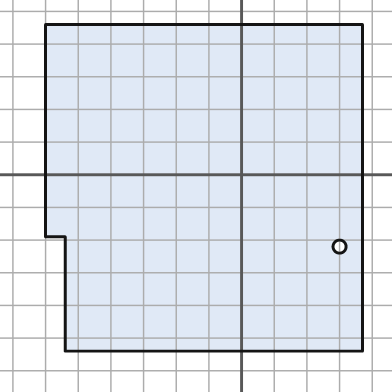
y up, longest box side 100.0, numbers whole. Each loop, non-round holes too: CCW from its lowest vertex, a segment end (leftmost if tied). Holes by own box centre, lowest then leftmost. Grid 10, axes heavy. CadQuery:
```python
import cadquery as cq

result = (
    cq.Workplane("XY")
    .moveTo(-54.0, -54.0)
    .lineTo(37.0, -54.0)
    .lineTo(37.0, 46.0)
    .lineTo(-60.0, 46.0)
    .lineTo(-60.0, -19.0)
    .lineTo(-54.0, -19.0)
    .close()
    .moveTo(30.0, -22.0)
    .circle(2.0)
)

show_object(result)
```